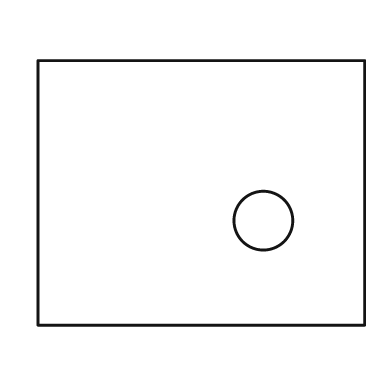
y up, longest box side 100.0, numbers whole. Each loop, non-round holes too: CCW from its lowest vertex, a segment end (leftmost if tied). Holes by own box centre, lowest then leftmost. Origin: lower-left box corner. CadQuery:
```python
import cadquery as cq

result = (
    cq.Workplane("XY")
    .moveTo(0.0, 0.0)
    .lineTo(100.0, 0.0)
    .lineTo(100.0, 81.0)
    .lineTo(0.0, 81.0)
    .close()
    .moveTo(69.0, 32.0)
    .circle(9.0)
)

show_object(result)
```